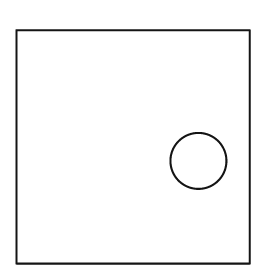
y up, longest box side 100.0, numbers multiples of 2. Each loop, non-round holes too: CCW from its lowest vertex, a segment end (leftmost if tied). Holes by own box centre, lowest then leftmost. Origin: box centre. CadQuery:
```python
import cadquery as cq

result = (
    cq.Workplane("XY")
    .moveTo(-50.0, -50.0)
    .lineTo(50.0, -50.0)
    .lineTo(50.0, 50.0)
    .lineTo(-50.0, 50.0)
    .close()
    .moveTo(28.0, -6.0)
    .circle(12.0)
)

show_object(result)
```